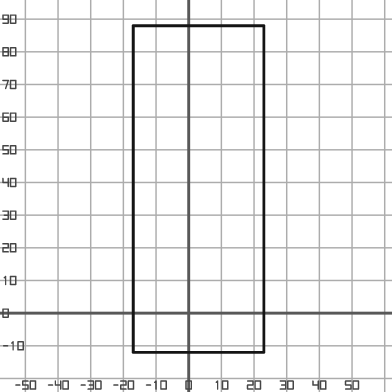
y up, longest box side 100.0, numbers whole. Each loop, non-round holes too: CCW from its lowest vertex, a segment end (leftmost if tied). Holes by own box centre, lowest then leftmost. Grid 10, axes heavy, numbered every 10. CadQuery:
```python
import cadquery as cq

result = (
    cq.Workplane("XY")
    .moveTo(-17.0, -12.0)
    .lineTo(23.0, -12.0)
    .lineTo(23.0, 88.0)
    .lineTo(-17.0, 88.0)
    .close()
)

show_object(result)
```